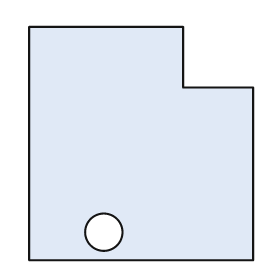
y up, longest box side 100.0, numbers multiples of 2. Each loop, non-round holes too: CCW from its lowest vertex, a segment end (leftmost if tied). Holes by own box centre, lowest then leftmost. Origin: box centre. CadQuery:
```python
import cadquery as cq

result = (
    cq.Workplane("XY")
    .moveTo(-48.0, -50.0)
    .lineTo(48.0, -50.0)
    .lineTo(48.0, 24.0)
    .lineTo(18.0, 24.0)
    .lineTo(18.0, 50.0)
    .lineTo(-48.0, 50.0)
    .close()
    .moveTo(-16.0, -38.0)
    .circle(8.0)
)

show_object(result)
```